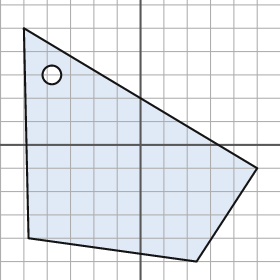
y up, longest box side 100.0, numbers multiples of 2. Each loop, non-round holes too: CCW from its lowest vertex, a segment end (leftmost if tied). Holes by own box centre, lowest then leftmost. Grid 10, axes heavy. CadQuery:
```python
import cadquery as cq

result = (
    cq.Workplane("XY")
    .moveTo(24.0, -50.0)
    .lineTo(50.0, -10.0)
    .lineTo(-50.0, 50.0)
    .lineTo(-48.0, -40.0)
    .close()
    .moveTo(-38.0, 30.0)
    .circle(4.0)
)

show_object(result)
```